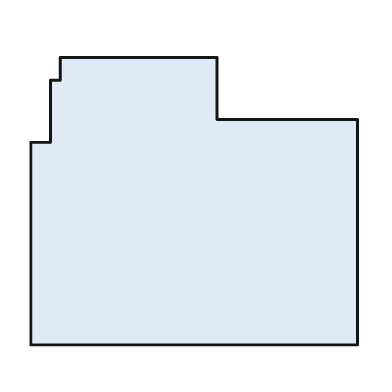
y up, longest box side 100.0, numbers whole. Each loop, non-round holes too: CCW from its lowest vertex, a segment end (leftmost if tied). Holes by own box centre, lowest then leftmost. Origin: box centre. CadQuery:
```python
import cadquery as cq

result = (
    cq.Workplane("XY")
    .moveTo(-50.0, -44.0)
    .lineTo(50.0, -44.0)
    .lineTo(50.0, 25.0)
    .lineTo(7.0, 25.0)
    .lineTo(7.0, 44.0)
    .lineTo(-41.0, 44.0)
    .lineTo(-41.0, 37.0)
    .lineTo(-44.0, 37.0)
    .lineTo(-44.0, 18.0)
    .lineTo(-50.0, 18.0)
    .close()
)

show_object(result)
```